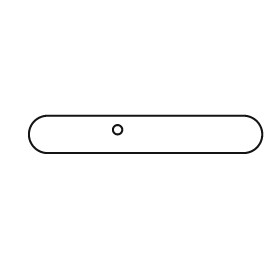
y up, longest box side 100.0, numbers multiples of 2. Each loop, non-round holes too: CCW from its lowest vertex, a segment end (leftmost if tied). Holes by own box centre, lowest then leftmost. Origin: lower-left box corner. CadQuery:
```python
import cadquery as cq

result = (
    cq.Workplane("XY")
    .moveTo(8.0, 0.0)
    .lineTo(92.0, 0.0)
    .threePointArc((100.0, 8.0), (92.0, 16.0))
    .lineTo(8.0, 16.0)
    .threePointArc((0.0, 8.0), (8.0, 0.0))
    .close()
    .moveTo(38.0, 10.0)
    .circle(2.0)
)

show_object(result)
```